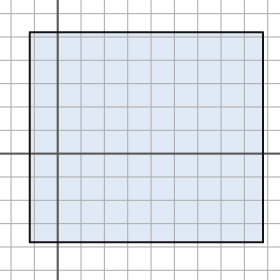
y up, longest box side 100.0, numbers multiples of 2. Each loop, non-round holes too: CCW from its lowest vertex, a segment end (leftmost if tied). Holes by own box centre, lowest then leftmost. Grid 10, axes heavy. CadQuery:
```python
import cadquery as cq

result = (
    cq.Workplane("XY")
    .moveTo(-12.0, -38.0)
    .lineTo(88.0, -38.0)
    .lineTo(88.0, 52.0)
    .lineTo(-12.0, 52.0)
    .close()
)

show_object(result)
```